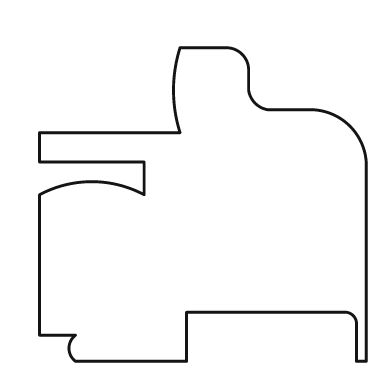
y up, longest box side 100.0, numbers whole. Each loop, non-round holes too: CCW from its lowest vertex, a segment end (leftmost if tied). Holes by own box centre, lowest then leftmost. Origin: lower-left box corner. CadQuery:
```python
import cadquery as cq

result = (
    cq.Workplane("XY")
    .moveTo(11.0, 0.0)
    .lineTo(45.0, 0.0)
    .lineTo(45.0, 15.0)
    .lineTo(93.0, 15.0)
    .threePointArc((96.0, 14.0), (97.0, 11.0))
    .lineTo(97.0, 0.0)
    .lineTo(100.0, 0.0)
    .lineTo(100.0, 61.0)
    .threePointArc((95.0, 72.0), (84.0, 77.0))
    .lineTo(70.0, 77.0)
    .threePointArc((66.0, 79.0), (64.0, 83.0))
    .lineTo(64.0, 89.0)
    .threePointArc((62.0, 94.0), (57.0, 96.0))
    .lineTo(43.0, 96.0)
    .threePointArc((41.0, 83.0), (43.0, 70.0))
    .lineTo(0.0, 70.0)
    .lineTo(0.0, 61.0)
    .lineTo(32.0, 61.0)
    .lineTo(32.0, 51.0)
    .threePointArc((16.0, 55.0), (0.0, 51.0))
    .lineTo(0.0, 8.0)
    .lineTo(11.0, 8.0)
    .threePointArc((9.0, 4.0), (11.0, 0.0))
    .close()
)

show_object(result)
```